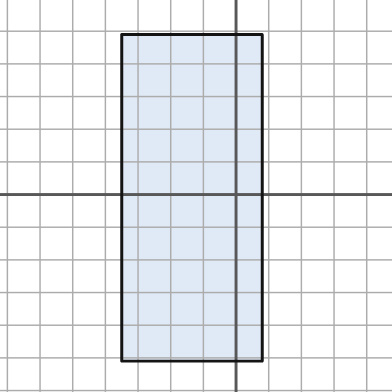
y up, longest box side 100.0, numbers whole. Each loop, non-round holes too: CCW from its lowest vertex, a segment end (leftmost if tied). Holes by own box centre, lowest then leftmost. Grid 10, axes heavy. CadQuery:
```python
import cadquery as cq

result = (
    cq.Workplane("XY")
    .moveTo(-35.0, -51.0)
    .lineTo(8.0, -51.0)
    .lineTo(8.0, 49.0)
    .lineTo(-35.0, 49.0)
    .close()
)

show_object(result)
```